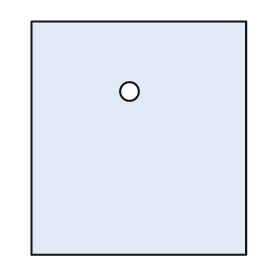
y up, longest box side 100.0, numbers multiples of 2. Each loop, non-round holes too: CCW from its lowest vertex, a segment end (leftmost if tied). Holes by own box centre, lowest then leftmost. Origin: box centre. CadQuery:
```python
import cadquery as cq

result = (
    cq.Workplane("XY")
    .moveTo(-46.0, -50.0)
    .lineTo(46.0, -50.0)
    .lineTo(46.0, 50.0)
    .lineTo(-46.0, 50.0)
    .close()
    .moveTo(-4.0, 20.0)
    .circle(4.0)
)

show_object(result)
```